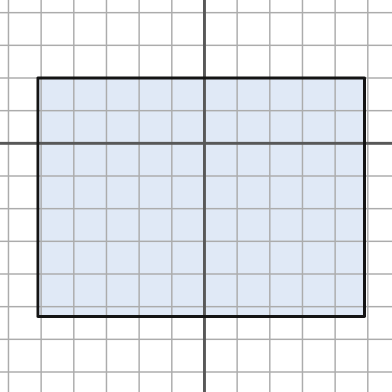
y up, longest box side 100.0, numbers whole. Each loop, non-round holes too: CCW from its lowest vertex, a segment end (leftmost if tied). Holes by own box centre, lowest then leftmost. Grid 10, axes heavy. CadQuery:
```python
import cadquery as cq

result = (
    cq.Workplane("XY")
    .moveTo(-51.0, -53.0)
    .lineTo(49.0, -53.0)
    .lineTo(49.0, 20.0)
    .lineTo(-51.0, 20.0)
    .close()
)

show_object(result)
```